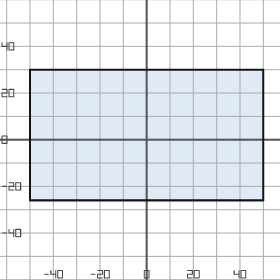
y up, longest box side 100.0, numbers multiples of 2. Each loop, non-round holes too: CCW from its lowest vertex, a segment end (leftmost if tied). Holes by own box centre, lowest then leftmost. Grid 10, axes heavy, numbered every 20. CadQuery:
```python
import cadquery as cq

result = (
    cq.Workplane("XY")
    .moveTo(-50.0, -26.0)
    .lineTo(50.0, -26.0)
    .lineTo(50.0, 30.0)
    .lineTo(-50.0, 30.0)
    .close()
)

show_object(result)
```